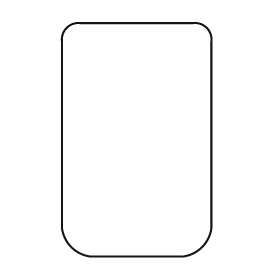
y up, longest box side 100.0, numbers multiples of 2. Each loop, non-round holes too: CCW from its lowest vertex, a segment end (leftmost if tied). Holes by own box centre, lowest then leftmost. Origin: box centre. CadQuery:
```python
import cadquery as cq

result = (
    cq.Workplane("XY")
    .moveTo(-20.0, -50.0)
    .lineTo(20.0, -50.0)
    .threePointArc((28.0, -46.0), (32.0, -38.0))
    .lineTo(32.0, 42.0)
    .threePointArc((30.0, 48.0), (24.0, 50.0))
    .lineTo(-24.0, 50.0)
    .threePointArc((-30.0, 48.0), (-32.0, 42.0))
    .lineTo(-32.0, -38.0)
    .threePointArc((-28.0, -46.0), (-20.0, -50.0))
    .close()
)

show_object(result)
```